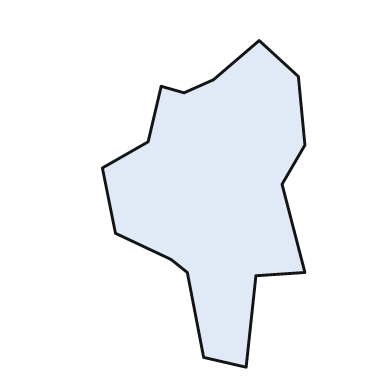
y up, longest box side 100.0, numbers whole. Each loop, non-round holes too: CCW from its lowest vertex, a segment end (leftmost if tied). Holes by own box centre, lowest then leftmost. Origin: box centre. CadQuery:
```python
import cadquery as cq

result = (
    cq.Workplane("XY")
    .moveTo(13.0, -50.0)
    .lineTo(16.0, -22.0)
    .lineTo(31.0, -21.0)
    .lineTo(24.0, 6.0)
    .lineTo(31.0, 18.0)
    .lineTo(29.0, 39.0)
    .lineTo(17.0, 50.0)
    .lineTo(3.0, 38.0)
    .lineTo(-6.0, 34.0)
    .lineTo(-13.0, 36.0)
    .lineTo(-17.0, 19.0)
    .lineTo(-31.0, 11.0)
    .lineTo(-27.0, -9.0)
    .lineTo(-10.0, -17.0)
    .lineTo(-5.0, -21.0)
    .lineTo(0.0, -47.0)
    .close()
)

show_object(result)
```